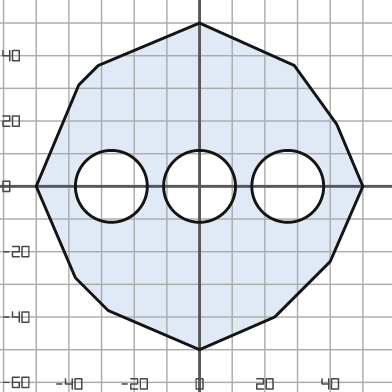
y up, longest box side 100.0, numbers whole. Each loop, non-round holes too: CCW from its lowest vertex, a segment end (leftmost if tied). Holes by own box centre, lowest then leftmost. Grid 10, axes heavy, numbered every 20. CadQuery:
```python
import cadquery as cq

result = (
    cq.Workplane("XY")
    .moveTo(0.0, -50.0)
    .lineTo(23.0, -40.0)
    .lineTo(40.0, -23.0)
    .lineTo(50.0, 0.0)
    .lineTo(42.0, 19.0)
    .lineTo(29.0, 37.0)
    .lineTo(0.0, 50.0)
    .lineTo(-31.0, 37.0)
    .lineTo(-37.0, 31.0)
    .lineTo(-50.0, 0.0)
    .lineTo(-38.0, -28.0)
    .lineTo(-28.0, -38.0)
    .close()
    .moveTo(-27.0, 0.0)
    .circle(11.0)
    .moveTo(0.0, 0.0)
    .circle(11.0)
    .moveTo(27.0, 0.0)
    .circle(11.0)
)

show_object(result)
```